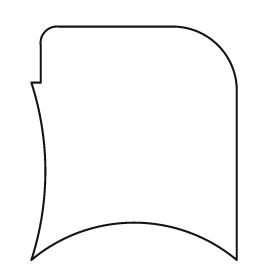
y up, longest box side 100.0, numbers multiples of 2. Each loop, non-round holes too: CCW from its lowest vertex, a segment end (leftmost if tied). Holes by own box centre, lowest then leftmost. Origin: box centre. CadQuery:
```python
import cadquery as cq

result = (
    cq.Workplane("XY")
    .moveTo(-44.0, -50.0)
    .threePointArc((0.0, -34.0), (44.0, -50.0))
    .lineTo(44.0, 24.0)
    .threePointArc((36.0, 42.0), (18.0, 50.0))
    .lineTo(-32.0, 50.0)
    .threePointArc((-38.0, 48.0), (-40.0, 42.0))
    .lineTo(-40.0, 26.0)
    .lineTo(-44.0, 26.0)
    .threePointArc((-38.0, -12.0), (-44.0, -50.0))
    .close()
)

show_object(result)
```